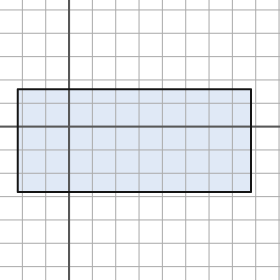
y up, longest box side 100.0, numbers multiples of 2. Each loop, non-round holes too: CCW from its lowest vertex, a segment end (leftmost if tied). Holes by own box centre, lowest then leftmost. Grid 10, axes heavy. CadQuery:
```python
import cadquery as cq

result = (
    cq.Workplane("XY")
    .moveTo(-22.0, -28.0)
    .lineTo(78.0, -28.0)
    .lineTo(78.0, 16.0)
    .lineTo(-22.0, 16.0)
    .close()
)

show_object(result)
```